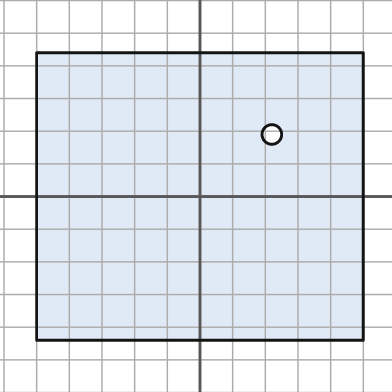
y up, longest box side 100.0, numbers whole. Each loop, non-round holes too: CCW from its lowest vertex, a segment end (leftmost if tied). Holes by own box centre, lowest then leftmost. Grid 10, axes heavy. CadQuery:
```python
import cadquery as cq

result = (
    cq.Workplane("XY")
    .moveTo(-50.0, -44.0)
    .lineTo(50.0, -44.0)
    .lineTo(50.0, 44.0)
    .lineTo(-50.0, 44.0)
    .close()
    .moveTo(22.0, 19.0)
    .circle(3.0)
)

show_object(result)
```